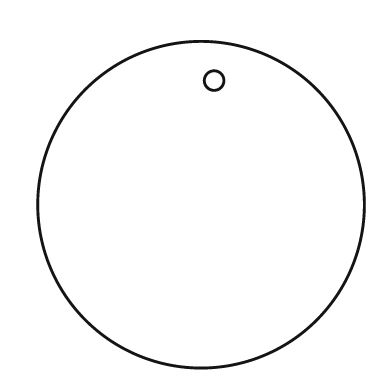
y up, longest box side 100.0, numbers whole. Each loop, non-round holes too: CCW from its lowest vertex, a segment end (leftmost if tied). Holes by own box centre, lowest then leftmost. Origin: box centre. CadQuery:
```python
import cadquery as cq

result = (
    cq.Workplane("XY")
    .moveTo(0.0, 0.0)
    .circle(50.0)
    .moveTo(4.0, 38.0)
    .circle(3.0)
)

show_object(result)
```